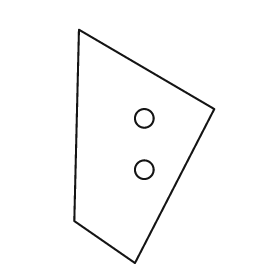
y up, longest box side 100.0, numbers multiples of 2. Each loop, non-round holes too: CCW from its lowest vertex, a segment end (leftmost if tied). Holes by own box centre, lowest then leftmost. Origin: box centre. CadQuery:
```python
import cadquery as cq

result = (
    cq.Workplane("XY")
    .moveTo(-4.0, -50.0)
    .lineTo(30.0, 16.0)
    .lineTo(-28.0, 50.0)
    .lineTo(-30.0, -32.0)
    .close()
    .moveTo(0.0, -10.0)
    .circle(4.0)
    .moveTo(0.0, 12.0)
    .circle(4.0)
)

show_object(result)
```